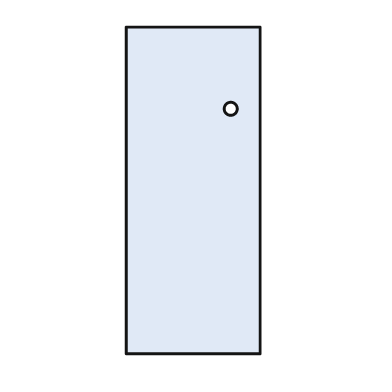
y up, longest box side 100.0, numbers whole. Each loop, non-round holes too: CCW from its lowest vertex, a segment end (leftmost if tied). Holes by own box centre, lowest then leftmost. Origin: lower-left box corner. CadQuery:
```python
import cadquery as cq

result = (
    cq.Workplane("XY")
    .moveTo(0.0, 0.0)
    .lineTo(41.0, 0.0)
    .lineTo(41.0, 100.0)
    .lineTo(0.0, 100.0)
    .close()
    .moveTo(32.0, 75.0)
    .circle(2.0)
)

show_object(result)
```